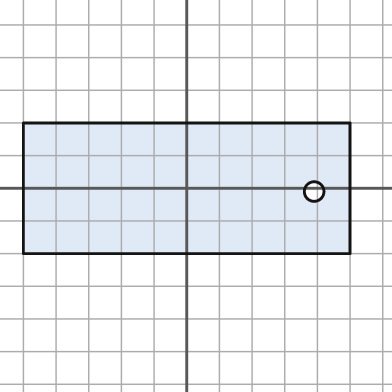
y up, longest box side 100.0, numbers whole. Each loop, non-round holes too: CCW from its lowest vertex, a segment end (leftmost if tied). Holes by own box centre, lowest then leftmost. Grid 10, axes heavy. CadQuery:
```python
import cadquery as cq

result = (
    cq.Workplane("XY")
    .moveTo(-50.0, -20.0)
    .lineTo(50.0, -20.0)
    .lineTo(50.0, 20.0)
    .lineTo(-50.0, 20.0)
    .close()
    .moveTo(39.0, -1.0)
    .circle(3.0)
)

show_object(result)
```